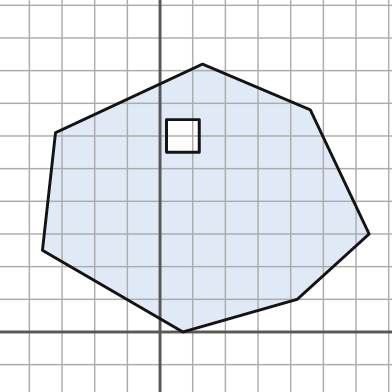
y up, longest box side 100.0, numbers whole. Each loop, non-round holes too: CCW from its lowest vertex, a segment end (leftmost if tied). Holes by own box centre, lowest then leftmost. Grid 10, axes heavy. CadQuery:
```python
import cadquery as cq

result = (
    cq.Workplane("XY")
    .moveTo(7.0, 0.0)
    .lineTo(42.0, 10.0)
    .lineTo(64.0, 30.0)
    .lineTo(46.0, 68.0)
    .lineTo(13.0, 82.0)
    .lineTo(-32.0, 61.0)
    .lineTo(-36.0, 25.0)
    .close()
    .moveTo(2.0, 55.0)
    .lineTo(12.0, 55.0)
    .lineTo(12.0, 65.0)
    .lineTo(2.0, 65.0)
    .close()
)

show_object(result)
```